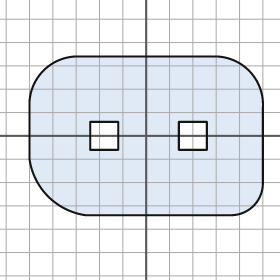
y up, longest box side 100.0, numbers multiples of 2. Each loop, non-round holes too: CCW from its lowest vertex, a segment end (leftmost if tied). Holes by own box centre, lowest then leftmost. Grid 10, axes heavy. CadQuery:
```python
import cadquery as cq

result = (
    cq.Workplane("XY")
    .moveTo(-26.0, -34.0)
    .lineTo(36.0, -34.0)
    .threePointArc((46.0, -30.0), (50.0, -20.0))
    .lineTo(50.0, 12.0)
    .threePointArc((44.0, 28.0), (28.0, 34.0))
    .lineTo(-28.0, 34.0)
    .threePointArc((-44.0, 28.0), (-50.0, 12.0))
    .lineTo(-50.0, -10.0)
    .threePointArc((-42.0, -26.0), (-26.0, -34.0))
    .close()
    .moveTo(-24.0, -6.0)
    .lineTo(-12.0, -6.0)
    .lineTo(-12.0, 6.0)
    .lineTo(-24.0, 6.0)
    .close()
    .moveTo(14.0, -6.0)
    .lineTo(26.0, -6.0)
    .lineTo(26.0, 6.0)
    .lineTo(14.0, 6.0)
    .close()
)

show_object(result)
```